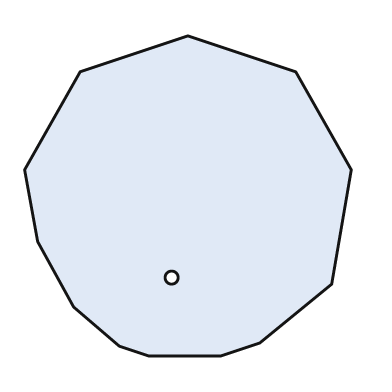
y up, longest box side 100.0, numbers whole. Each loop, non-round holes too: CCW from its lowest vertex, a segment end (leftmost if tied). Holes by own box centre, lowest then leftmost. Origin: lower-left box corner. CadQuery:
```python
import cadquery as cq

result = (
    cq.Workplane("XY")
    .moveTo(38.0, 0.0)
    .lineTo(60.0, 0.0)
    .lineTo(72.0, 4.0)
    .lineTo(94.0, 22.0)
    .lineTo(100.0, 57.0)
    .lineTo(83.0, 87.0)
    .lineTo(50.0, 98.0)
    .lineTo(17.0, 87.0)
    .lineTo(0.0, 57.0)
    .lineTo(4.0, 35.0)
    .lineTo(15.0, 15.0)
    .lineTo(29.0, 3.0)
    .close()
    .moveTo(45.0, 24.0)
    .circle(2.0)
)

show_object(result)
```